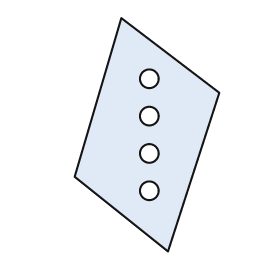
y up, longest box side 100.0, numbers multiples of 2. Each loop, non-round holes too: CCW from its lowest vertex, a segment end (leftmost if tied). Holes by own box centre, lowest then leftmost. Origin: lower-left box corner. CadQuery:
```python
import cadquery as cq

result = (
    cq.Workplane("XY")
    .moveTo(40.0, 0.0)
    .lineTo(62.0, 68.0)
    .lineTo(20.0, 100.0)
    .lineTo(0.0, 32.0)
    .close()
    .moveTo(32.0, 26.0)
    .circle(4.0)
    .moveTo(32.0, 42.0)
    .circle(4.0)
    .moveTo(32.0, 58.0)
    .circle(4.0)
    .moveTo(32.0, 74.0)
    .circle(4.0)
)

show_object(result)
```